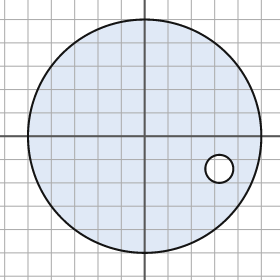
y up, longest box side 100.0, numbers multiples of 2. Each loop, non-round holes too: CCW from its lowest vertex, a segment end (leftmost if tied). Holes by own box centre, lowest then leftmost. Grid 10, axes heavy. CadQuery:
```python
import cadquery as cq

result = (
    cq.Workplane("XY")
    .moveTo(0.0, 0.0)
    .circle(50.0)
    .moveTo(32.0, -14.0)
    .circle(6.0)
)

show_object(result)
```